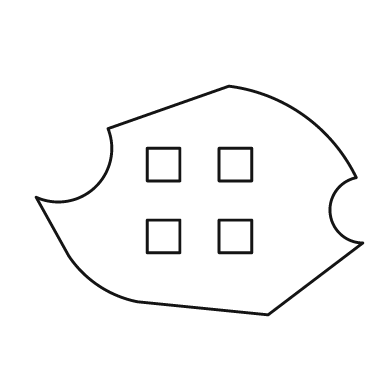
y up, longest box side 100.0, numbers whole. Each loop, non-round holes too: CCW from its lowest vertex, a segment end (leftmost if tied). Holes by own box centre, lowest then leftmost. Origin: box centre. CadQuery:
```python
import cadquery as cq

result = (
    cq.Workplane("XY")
    .moveTo(21.0, -35.0)
    .lineTo(50.0, -13.0)
    .threePointArc((40.0, -4.0), (48.0, 7.0))
    .threePointArc((32.0, 26.0), (9.0, 35.0))
    .lineTo(-28.0, 22.0)
    .threePointArc((-32.0, 4.0), (-50.0, 1.0))
    .lineTo(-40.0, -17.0)
    .threePointArc((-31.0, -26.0), (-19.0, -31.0))
    .close()
    .moveTo(-16.0, -16.0)
    .lineTo(-6.0, -16.0)
    .lineTo(-6.0, -6.0)
    .lineTo(-16.0, -6.0)
    .close()
    .moveTo(6.0, -16.0)
    .lineTo(16.0, -16.0)
    .lineTo(16.0, -6.0)
    .lineTo(6.0, -6.0)
    .close()
    .moveTo(-16.0, 6.0)
    .lineTo(-6.0, 6.0)
    .lineTo(-6.0, 16.0)
    .lineTo(-16.0, 16.0)
    .close()
    .moveTo(6.0, 6.0)
    .lineTo(16.0, 6.0)
    .lineTo(16.0, 16.0)
    .lineTo(6.0, 16.0)
    .close()
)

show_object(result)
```